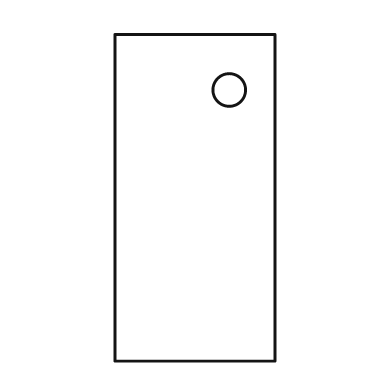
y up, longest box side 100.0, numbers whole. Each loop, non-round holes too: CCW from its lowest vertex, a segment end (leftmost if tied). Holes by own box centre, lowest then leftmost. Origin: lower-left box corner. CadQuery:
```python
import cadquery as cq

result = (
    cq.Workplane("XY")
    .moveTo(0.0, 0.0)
    .lineTo(49.0, 0.0)
    .lineTo(49.0, 100.0)
    .lineTo(0.0, 100.0)
    .close()
    .moveTo(35.0, 83.0)
    .circle(5.0)
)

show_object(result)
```